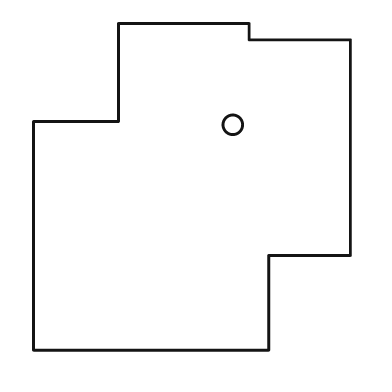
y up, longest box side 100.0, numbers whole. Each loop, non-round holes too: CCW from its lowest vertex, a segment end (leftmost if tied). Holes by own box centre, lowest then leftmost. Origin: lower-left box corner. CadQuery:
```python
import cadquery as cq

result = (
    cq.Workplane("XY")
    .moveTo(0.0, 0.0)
    .lineTo(72.0, 0.0)
    .lineTo(72.0, 29.0)
    .lineTo(97.0, 29.0)
    .lineTo(97.0, 95.0)
    .lineTo(66.0, 95.0)
    .lineTo(66.0, 100.0)
    .lineTo(26.0, 100.0)
    .lineTo(26.0, 70.0)
    .lineTo(0.0, 70.0)
    .close()
    .moveTo(61.0, 69.0)
    .circle(3.0)
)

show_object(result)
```